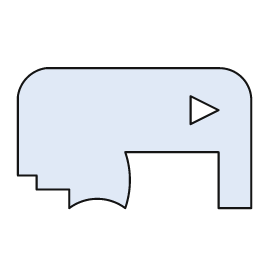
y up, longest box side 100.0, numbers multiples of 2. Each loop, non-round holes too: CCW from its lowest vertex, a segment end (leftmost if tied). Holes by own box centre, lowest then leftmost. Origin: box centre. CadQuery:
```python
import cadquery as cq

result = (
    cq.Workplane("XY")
    .moveTo(-28.0, -30.0)
    .threePointArc((-16.0, -26.0), (-4.0, -30.0))
    .threePointArc((-2.0, -18.0), (-4.0, -6.0))
    .lineTo(36.0, -6.0)
    .lineTo(36.0, -30.0)
    .lineTo(50.0, -30.0)
    .lineTo(50.0, 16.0)
    .threePointArc((46.0, 26.0), (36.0, 30.0))
    .lineTo(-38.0, 30.0)
    .threePointArc((-46.0, 26.0), (-50.0, 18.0))
    .lineTo(-50.0, -16.0)
    .lineTo(-42.0, -16.0)
    .lineTo(-42.0, -22.0)
    .lineTo(-28.0, -22.0)
    .close()
    .moveTo(24.0, 6.0)
    .lineTo(36.0, 12.0)
    .lineTo(24.0, 18.0)
    .close()
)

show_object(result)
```